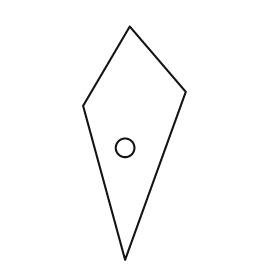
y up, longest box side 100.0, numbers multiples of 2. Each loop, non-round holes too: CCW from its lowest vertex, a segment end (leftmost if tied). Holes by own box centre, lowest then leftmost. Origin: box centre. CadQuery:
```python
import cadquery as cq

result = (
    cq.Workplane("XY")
    .moveTo(-4.0, -50.0)
    .lineTo(22.0, 22.0)
    .lineTo(-2.0, 50.0)
    .lineTo(-22.0, 16.0)
    .close()
    .moveTo(-4.0, -2.0)
    .circle(4.0)
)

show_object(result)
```